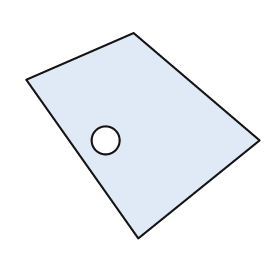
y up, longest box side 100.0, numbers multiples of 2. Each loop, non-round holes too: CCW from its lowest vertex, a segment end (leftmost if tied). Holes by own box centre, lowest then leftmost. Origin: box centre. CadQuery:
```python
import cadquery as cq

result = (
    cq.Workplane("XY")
    .moveTo(-2.0, -44.0)
    .lineTo(50.0, -2.0)
    .lineTo(-4.0, 44.0)
    .lineTo(-50.0, 24.0)
    .close()
    .moveTo(-16.0, -2.0)
    .circle(6.0)
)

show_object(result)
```